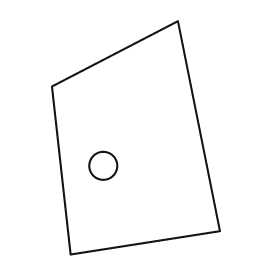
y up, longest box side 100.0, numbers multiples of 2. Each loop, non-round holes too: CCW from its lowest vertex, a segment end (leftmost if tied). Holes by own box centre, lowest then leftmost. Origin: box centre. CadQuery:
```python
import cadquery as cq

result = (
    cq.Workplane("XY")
    .moveTo(-28.0, -50.0)
    .lineTo(36.0, -40.0)
    .lineTo(18.0, 50.0)
    .lineTo(-36.0, 22.0)
    .close()
    .moveTo(-14.0, -12.0)
    .circle(6.0)
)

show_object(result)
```